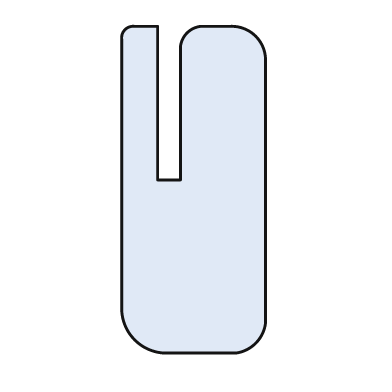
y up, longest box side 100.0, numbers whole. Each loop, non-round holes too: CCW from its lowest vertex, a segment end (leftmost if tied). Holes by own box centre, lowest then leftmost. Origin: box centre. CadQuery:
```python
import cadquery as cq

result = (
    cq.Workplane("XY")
    .moveTo(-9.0, -50.0)
    .lineTo(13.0, -50.0)
    .threePointArc((19.0, -47.0), (22.0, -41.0))
    .lineTo(22.0, 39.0)
    .threePointArc((19.0, 47.0), (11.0, 50.0))
    .lineTo(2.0, 50.0)
    .threePointArc((-2.0, 48.0), (-4.0, 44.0))
    .lineTo(-4.0, 3.0)
    .lineTo(-11.0, 3.0)
    .lineTo(-11.0, 50.0)
    .lineTo(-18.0, 50.0)
    .threePointArc((-21.0, 49.0), (-22.0, 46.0))
    .lineTo(-22.0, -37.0)
    .threePointArc((-18.0, -46.0), (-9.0, -50.0))
    .close()
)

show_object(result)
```